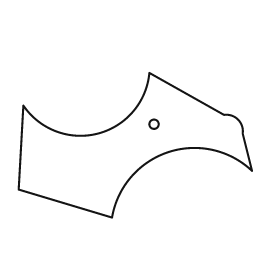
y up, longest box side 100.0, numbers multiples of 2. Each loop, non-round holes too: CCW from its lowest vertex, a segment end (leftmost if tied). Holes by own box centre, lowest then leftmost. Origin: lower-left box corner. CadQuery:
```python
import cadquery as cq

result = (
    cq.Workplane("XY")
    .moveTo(40.0, 0.0)
    .threePointArc((64.0, 28.0), (100.0, 20.0))
    .lineTo(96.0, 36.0)
    .threePointArc((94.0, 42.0), (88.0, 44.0))
    .lineTo(56.0, 62.0)
    .threePointArc((34.0, 36.0), (2.0, 48.0))
    .lineTo(0.0, 12.0)
    .close()
    .moveTo(58.0, 40.0)
    .circle(2.0)
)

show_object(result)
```